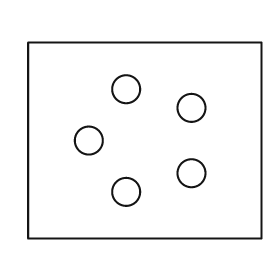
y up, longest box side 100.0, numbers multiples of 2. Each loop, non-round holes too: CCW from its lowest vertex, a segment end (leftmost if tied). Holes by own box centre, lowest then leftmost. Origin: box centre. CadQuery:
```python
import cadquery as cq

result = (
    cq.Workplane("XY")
    .moveTo(-50.0, -42.0)
    .lineTo(50.0, -42.0)
    .lineTo(50.0, 42.0)
    .lineTo(-50.0, 42.0)
    .close()
    .moveTo(-8.0, -22.0)
    .circle(6.0)
    .moveTo(20.0, -14.0)
    .circle(6.0)
    .moveTo(-24.0, 0.0)
    .circle(6.0)
    .moveTo(20.0, 14.0)
    .circle(6.0)
    .moveTo(-8.0, 22.0)
    .circle(6.0)
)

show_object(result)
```